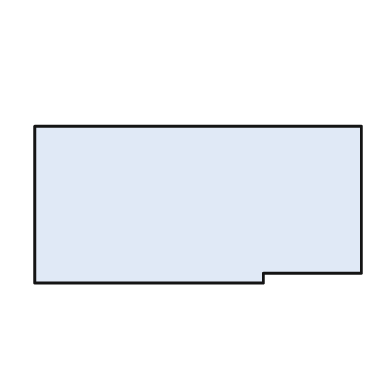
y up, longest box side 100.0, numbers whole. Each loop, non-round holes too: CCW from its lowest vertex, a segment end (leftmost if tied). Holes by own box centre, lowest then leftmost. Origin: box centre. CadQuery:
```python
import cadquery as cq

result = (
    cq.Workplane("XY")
    .moveTo(-50.0, -24.0)
    .lineTo(20.0, -24.0)
    .lineTo(20.0, -21.0)
    .lineTo(50.0, -21.0)
    .lineTo(50.0, 24.0)
    .lineTo(-50.0, 24.0)
    .close()
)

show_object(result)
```